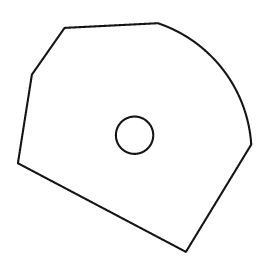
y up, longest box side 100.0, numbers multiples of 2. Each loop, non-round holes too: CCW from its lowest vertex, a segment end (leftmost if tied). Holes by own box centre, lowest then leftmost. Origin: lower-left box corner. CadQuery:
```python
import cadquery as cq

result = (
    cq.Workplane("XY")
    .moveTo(72.0, 0.0)
    .lineTo(100.0, 46.0)
    .threePointArc((88.0, 78.0), (60.0, 98.0))
    .lineTo(20.0, 96.0)
    .lineTo(6.0, 76.0)
    .lineTo(0.0, 38.0)
    .close()
    .moveTo(50.0, 50.0)
    .circle(8.0)
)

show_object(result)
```